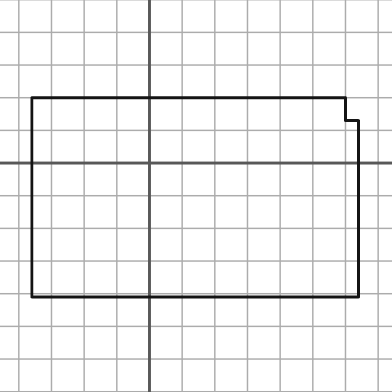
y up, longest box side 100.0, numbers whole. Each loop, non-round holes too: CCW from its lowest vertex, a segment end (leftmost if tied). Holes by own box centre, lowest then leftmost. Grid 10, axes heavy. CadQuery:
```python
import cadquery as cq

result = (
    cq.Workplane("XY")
    .moveTo(-36.0, -41.0)
    .lineTo(64.0, -41.0)
    .lineTo(64.0, 13.0)
    .lineTo(60.0, 13.0)
    .lineTo(60.0, 20.0)
    .lineTo(-36.0, 20.0)
    .close()
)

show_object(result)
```